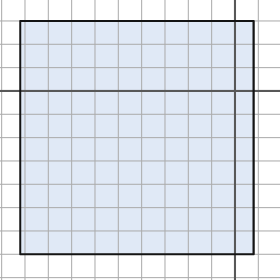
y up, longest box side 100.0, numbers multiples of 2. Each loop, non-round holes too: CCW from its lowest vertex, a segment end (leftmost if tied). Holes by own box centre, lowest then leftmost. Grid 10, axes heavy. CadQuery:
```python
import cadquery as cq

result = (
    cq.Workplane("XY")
    .moveTo(-92.0, -70.0)
    .lineTo(8.0, -70.0)
    .lineTo(8.0, 30.0)
    .lineTo(-92.0, 30.0)
    .close()
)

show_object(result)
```